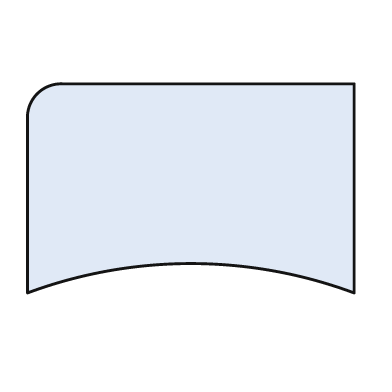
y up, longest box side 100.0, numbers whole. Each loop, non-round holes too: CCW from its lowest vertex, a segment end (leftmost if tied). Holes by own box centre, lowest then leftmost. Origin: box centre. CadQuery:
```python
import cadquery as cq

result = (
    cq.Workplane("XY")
    .moveTo(-50.0, -32.0)
    .threePointArc((0.0, -23.0), (50.0, -32.0))
    .lineTo(50.0, 32.0)
    .lineTo(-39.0, 32.0)
    .threePointArc((-47.0, 29.0), (-50.0, 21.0))
    .close()
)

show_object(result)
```